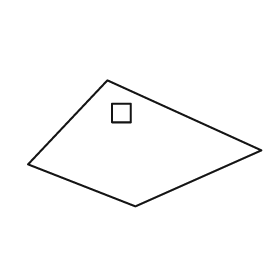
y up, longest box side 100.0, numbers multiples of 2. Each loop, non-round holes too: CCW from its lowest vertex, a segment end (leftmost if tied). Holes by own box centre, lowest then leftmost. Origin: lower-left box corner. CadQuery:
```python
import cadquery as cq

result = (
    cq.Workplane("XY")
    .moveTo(46.0, 0.0)
    .lineTo(100.0, 24.0)
    .lineTo(34.0, 54.0)
    .lineTo(0.0, 18.0)
    .close()
    .moveTo(36.0, 36.0)
    .lineTo(44.0, 36.0)
    .lineTo(44.0, 44.0)
    .lineTo(36.0, 44.0)
    .close()
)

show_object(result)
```